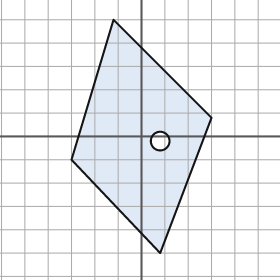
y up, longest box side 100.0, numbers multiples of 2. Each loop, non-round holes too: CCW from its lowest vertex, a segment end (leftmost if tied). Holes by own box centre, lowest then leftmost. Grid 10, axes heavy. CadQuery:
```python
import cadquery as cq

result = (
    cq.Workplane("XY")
    .moveTo(8.0, -50.0)
    .lineTo(30.0, 8.0)
    .lineTo(-12.0, 50.0)
    .lineTo(-30.0, -10.0)
    .close()
    .moveTo(8.0, -2.0)
    .circle(4.0)
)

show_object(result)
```